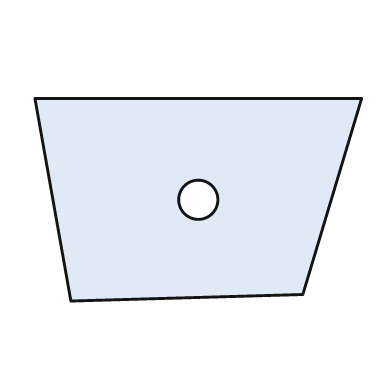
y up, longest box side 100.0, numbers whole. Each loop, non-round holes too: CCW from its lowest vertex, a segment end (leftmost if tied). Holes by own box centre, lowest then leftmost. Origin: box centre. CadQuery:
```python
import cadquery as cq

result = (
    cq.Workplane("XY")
    .moveTo(-39.0, -31.0)
    .lineTo(32.0, -29.0)
    .lineTo(50.0, 31.0)
    .lineTo(-50.0, 31.0)
    .close()
    .moveTo(0.0, 0.0)
    .circle(6.0)
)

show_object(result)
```